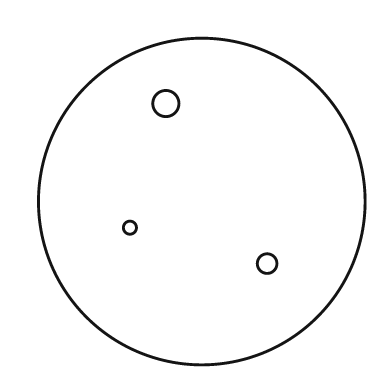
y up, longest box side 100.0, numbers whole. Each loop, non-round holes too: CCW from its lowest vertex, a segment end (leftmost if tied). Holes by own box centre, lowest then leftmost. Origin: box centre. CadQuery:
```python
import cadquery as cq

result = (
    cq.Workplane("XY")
    .moveTo(0.0, 0.0)
    .circle(50.0)
    .moveTo(20.0, -19.0)
    .circle(3.0)
    .moveTo(-22.0, -8.0)
    .circle(2.0)
    .moveTo(-11.0, 30.0)
    .circle(4.0)
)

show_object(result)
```